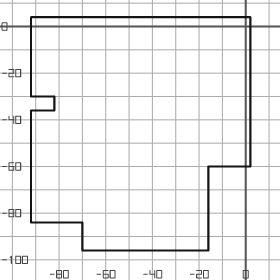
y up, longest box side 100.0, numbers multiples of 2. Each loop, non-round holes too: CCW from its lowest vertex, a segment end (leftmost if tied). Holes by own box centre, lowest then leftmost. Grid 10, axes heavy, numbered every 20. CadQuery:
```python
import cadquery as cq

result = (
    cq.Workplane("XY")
    .moveTo(-70.0, -96.0)
    .lineTo(-16.0, -96.0)
    .lineTo(-16.0, -60.0)
    .lineTo(2.0, -60.0)
    .lineTo(2.0, 4.0)
    .lineTo(-92.0, 4.0)
    .lineTo(-92.0, -30.0)
    .lineTo(-82.0, -30.0)
    .lineTo(-82.0, -36.0)
    .lineTo(-92.0, -36.0)
    .lineTo(-92.0, -84.0)
    .lineTo(-70.0, -84.0)
    .close()
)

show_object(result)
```